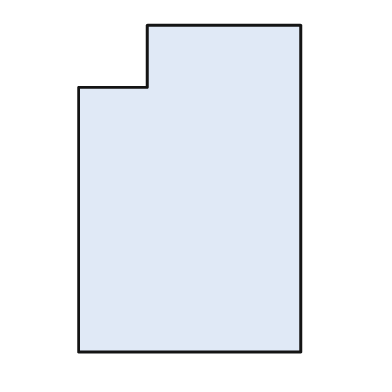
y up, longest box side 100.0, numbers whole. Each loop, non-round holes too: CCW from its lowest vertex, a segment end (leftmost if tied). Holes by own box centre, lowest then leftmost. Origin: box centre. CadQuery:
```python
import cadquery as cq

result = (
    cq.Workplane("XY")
    .moveTo(-34.0, -50.0)
    .lineTo(34.0, -50.0)
    .lineTo(34.0, 50.0)
    .lineTo(-13.0, 50.0)
    .lineTo(-13.0, 31.0)
    .lineTo(-34.0, 31.0)
    .close()
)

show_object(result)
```